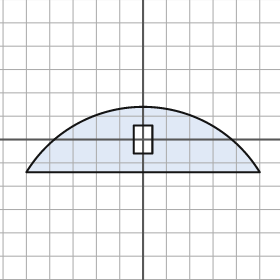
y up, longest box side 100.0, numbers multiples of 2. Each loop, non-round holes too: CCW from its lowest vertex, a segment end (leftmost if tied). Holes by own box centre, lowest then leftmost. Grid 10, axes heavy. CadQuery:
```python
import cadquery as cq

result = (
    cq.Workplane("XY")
    .moveTo(-50.0, -14.0)
    .lineTo(50.0, -14.0)
    .threePointArc((0.0, 14.0), (-50.0, -14.0))
    .close()
    .moveTo(-4.0, -6.0)
    .lineTo(4.0, -6.0)
    .lineTo(4.0, 6.0)
    .lineTo(-4.0, 6.0)
    .close()
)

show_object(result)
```